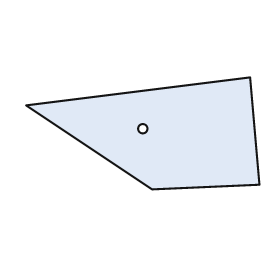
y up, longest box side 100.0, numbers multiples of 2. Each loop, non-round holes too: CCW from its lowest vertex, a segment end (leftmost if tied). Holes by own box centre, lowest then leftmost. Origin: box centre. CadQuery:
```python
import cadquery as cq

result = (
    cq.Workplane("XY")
    .moveTo(4.0, -24.0)
    .lineTo(50.0, -22.0)
    .lineTo(46.0, 24.0)
    .lineTo(-50.0, 12.0)
    .close()
    .moveTo(0.0, 2.0)
    .circle(2.0)
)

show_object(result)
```